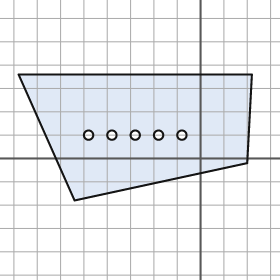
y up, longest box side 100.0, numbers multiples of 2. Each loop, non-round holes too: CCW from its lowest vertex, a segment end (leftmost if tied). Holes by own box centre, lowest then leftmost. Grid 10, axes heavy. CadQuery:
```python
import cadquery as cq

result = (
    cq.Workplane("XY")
    .moveTo(-54.0, -18.0)
    .lineTo(20.0, -2.0)
    .lineTo(22.0, 36.0)
    .lineTo(-78.0, 36.0)
    .close()
    .moveTo(-48.0, 10.0)
    .circle(2.0)
    .moveTo(-38.0, 10.0)
    .circle(2.0)
    .moveTo(-28.0, 10.0)
    .circle(2.0)
    .moveTo(-18.0, 10.0)
    .circle(2.0)
    .moveTo(-8.0, 10.0)
    .circle(2.0)
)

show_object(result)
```